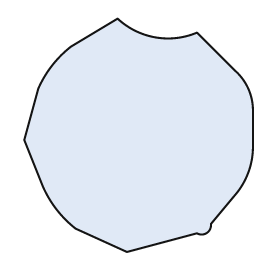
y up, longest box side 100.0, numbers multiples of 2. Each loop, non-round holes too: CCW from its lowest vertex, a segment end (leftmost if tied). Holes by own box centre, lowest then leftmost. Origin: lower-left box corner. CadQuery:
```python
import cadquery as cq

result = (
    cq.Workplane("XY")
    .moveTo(44.0, 0.0)
    .lineTo(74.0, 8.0)
    .threePointArc((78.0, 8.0), (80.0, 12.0))
    .lineTo(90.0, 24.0)
    .threePointArc((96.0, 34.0), (98.0, 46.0))
    .lineTo(98.0, 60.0)
    .threePointArc((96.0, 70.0), (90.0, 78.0))
    .lineTo(74.0, 94.0)
    .threePointArc((56.0, 92.0), (40.0, 100.0))
    .lineTo(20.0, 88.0)
    .threePointArc((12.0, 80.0), (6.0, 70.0))
    .lineTo(0.0, 48.0)
    .lineTo(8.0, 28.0)
    .threePointArc((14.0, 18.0), (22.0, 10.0))
    .close()
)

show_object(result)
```